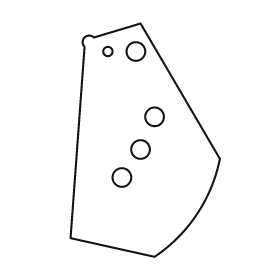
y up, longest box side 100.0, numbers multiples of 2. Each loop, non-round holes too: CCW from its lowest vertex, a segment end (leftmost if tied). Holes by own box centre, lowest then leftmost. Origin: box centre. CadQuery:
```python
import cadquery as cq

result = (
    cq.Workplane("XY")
    .moveTo(4.0, -50.0)
    .threePointArc((22.0, -32.0), (32.0, -8.0))
    .lineTo(-2.0, 50.0)
    .lineTo(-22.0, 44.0)
    .threePointArc((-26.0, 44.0), (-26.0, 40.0))
    .lineTo(-32.0, -42.0)
    .close()
    .moveTo(-10.0, -16.0)
    .circle(4.0)
    .moveTo(-2.0, -4.0)
    .circle(4.0)
    .moveTo(4.0, 10.0)
    .circle(4.0)
    .moveTo(-16.0, 38.0)
    .circle(2.0)
    .moveTo(-4.0, 38.0)
    .circle(4.0)
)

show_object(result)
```